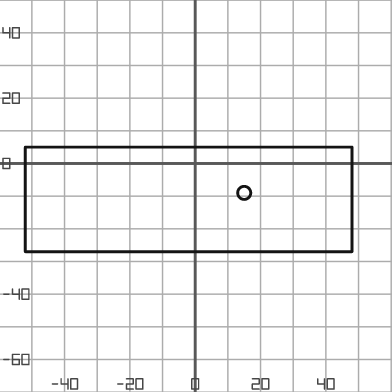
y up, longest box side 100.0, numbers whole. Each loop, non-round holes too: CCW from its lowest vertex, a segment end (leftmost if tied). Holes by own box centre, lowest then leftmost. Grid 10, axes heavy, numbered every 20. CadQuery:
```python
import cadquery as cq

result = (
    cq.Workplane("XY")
    .moveTo(-52.0, -27.0)
    .lineTo(48.0, -27.0)
    .lineTo(48.0, 5.0)
    .lineTo(-52.0, 5.0)
    .close()
    .moveTo(15.0, -9.0)
    .circle(2.0)
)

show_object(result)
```